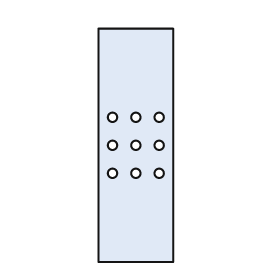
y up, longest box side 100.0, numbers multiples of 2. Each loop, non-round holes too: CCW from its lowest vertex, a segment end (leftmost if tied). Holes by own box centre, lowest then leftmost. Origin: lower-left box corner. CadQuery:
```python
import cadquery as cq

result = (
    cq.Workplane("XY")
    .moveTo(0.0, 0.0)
    .lineTo(32.0, 0.0)
    .lineTo(32.0, 100.0)
    .lineTo(0.0, 100.0)
    .close()
    .moveTo(6.0, 38.0)
    .circle(2.0)
    .moveTo(16.0, 38.0)
    .circle(2.0)
    .moveTo(26.0, 38.0)
    .circle(2.0)
    .moveTo(6.0, 50.0)
    .circle(2.0)
    .moveTo(16.0, 50.0)
    .circle(2.0)
    .moveTo(26.0, 50.0)
    .circle(2.0)
    .moveTo(6.0, 62.0)
    .circle(2.0)
    .moveTo(16.0, 62.0)
    .circle(2.0)
    .moveTo(26.0, 62.0)
    .circle(2.0)
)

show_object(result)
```